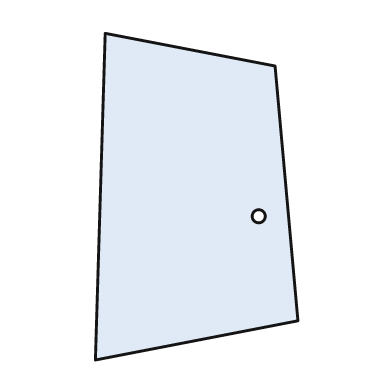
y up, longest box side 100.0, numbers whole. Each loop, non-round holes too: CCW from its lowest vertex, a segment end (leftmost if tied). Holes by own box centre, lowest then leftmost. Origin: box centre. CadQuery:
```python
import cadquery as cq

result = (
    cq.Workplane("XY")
    .moveTo(-31.0, -50.0)
    .lineTo(31.0, -38.0)
    .lineTo(24.0, 40.0)
    .lineTo(-28.0, 50.0)
    .close()
    .moveTo(19.0, -6.0)
    .circle(2.0)
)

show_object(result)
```